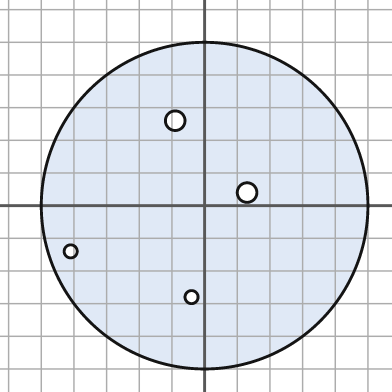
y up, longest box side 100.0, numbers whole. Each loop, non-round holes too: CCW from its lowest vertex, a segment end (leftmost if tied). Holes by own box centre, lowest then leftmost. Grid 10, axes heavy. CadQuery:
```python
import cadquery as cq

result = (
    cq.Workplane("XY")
    .moveTo(0.0, 0.0)
    .circle(50.0)
    .moveTo(-4.0, -28.0)
    .circle(2.0)
    .moveTo(-41.0, -14.0)
    .circle(2.0)
    .moveTo(13.0, 4.0)
    .circle(3.0)
    .moveTo(-9.0, 26.0)
    .circle(3.0)
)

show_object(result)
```